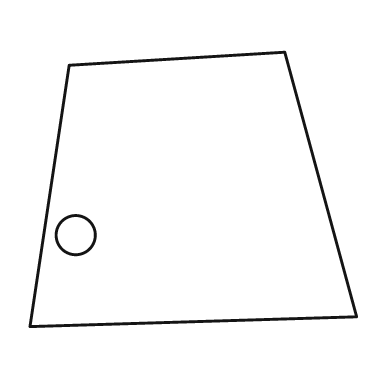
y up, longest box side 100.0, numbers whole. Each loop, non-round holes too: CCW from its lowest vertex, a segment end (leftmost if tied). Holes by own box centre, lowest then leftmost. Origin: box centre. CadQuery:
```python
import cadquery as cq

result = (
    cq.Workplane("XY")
    .moveTo(-50.0, -42.0)
    .lineTo(50.0, -39.0)
    .lineTo(28.0, 42.0)
    .lineTo(-38.0, 38.0)
    .close()
    .moveTo(-36.0, -14.0)
    .circle(6.0)
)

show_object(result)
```